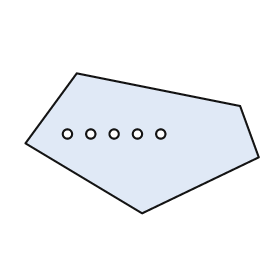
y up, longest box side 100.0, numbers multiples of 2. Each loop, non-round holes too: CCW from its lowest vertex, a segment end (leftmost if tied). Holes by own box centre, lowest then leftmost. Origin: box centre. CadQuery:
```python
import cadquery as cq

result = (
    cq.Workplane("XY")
    .moveTo(0.0, -30.0)
    .lineTo(50.0, -6.0)
    .lineTo(42.0, 16.0)
    .lineTo(-28.0, 30.0)
    .lineTo(-50.0, 0.0)
    .close()
    .moveTo(-32.0, 4.0)
    .circle(2.0)
    .moveTo(-22.0, 4.0)
    .circle(2.0)
    .moveTo(-12.0, 4.0)
    .circle(2.0)
    .moveTo(-2.0, 4.0)
    .circle(2.0)
    .moveTo(8.0, 4.0)
    .circle(2.0)
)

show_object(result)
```